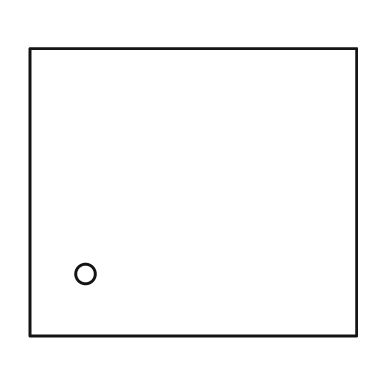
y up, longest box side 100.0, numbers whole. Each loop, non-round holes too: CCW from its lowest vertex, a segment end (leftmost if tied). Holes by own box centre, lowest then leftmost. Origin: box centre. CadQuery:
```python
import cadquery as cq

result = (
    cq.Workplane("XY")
    .moveTo(-50.0, -44.0)
    .lineTo(50.0, -44.0)
    .lineTo(50.0, 44.0)
    .lineTo(-50.0, 44.0)
    .close()
    .moveTo(-33.0, -25.0)
    .circle(3.0)
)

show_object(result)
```